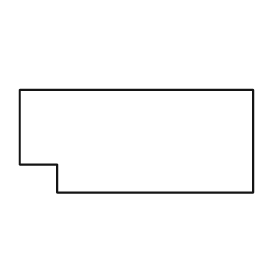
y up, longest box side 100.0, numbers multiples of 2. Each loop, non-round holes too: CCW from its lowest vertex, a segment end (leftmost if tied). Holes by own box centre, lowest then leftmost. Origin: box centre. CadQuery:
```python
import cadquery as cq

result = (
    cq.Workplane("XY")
    .moveTo(-34.0, -22.0)
    .lineTo(50.0, -22.0)
    .lineTo(50.0, 22.0)
    .lineTo(-50.0, 22.0)
    .lineTo(-50.0, -10.0)
    .lineTo(-34.0, -10.0)
    .close()
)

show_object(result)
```